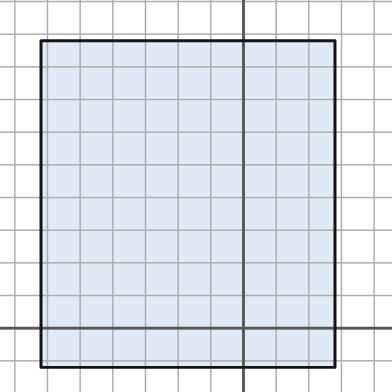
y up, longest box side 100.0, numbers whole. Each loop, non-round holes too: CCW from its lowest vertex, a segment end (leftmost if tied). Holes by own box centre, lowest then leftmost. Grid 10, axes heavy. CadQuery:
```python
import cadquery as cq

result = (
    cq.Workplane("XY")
    .moveTo(-62.0, -12.0)
    .lineTo(28.0, -12.0)
    .lineTo(28.0, 88.0)
    .lineTo(-62.0, 88.0)
    .close()
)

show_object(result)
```